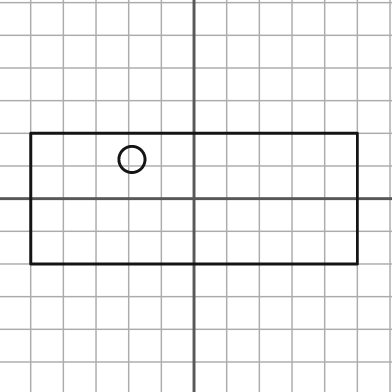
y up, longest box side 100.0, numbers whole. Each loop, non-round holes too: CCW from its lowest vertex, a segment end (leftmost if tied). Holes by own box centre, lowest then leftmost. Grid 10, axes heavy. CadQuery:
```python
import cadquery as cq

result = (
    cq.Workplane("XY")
    .moveTo(-50.0, -20.0)
    .lineTo(50.0, -20.0)
    .lineTo(50.0, 20.0)
    .lineTo(-50.0, 20.0)
    .close()
    .moveTo(-19.0, 12.0)
    .circle(4.0)
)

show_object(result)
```